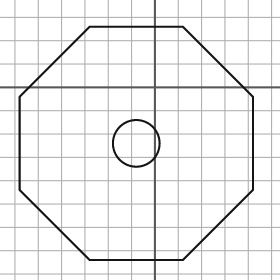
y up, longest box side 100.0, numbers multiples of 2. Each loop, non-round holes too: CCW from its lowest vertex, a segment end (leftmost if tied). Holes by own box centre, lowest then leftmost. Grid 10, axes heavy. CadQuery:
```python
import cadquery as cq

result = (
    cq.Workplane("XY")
    .moveTo(-28.0, -74.0)
    .lineTo(12.0, -74.0)
    .lineTo(42.0, -44.0)
    .lineTo(42.0, -4.0)
    .lineTo(12.0, 26.0)
    .lineTo(-28.0, 26.0)
    .lineTo(-58.0, -4.0)
    .lineTo(-58.0, -44.0)
    .close()
    .moveTo(-8.0, -24.0)
    .circle(10.0)
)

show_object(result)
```